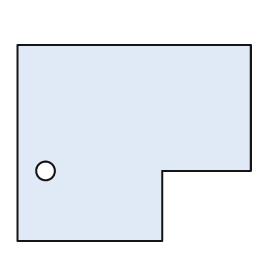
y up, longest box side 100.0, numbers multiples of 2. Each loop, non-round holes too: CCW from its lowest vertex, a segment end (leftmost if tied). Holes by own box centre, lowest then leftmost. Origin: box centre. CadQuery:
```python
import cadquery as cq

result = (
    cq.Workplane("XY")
    .moveTo(-50.0, -42.0)
    .lineTo(12.0, -42.0)
    .lineTo(12.0, -12.0)
    .lineTo(50.0, -12.0)
    .lineTo(50.0, 42.0)
    .lineTo(-50.0, 42.0)
    .close()
    .moveTo(-38.0, -12.0)
    .circle(4.0)
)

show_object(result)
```